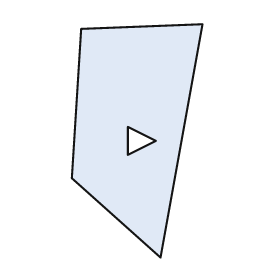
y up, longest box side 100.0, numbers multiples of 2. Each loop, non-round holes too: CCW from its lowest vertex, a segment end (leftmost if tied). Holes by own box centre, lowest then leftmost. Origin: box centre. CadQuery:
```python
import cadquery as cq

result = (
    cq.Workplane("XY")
    .moveTo(10.0, -50.0)
    .lineTo(28.0, 50.0)
    .lineTo(-24.0, 48.0)
    .lineTo(-28.0, -16.0)
    .close()
    .moveTo(-4.0, -6.0)
    .lineTo(8.0, 0.0)
    .lineTo(-4.0, 6.0)
    .close()
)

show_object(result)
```